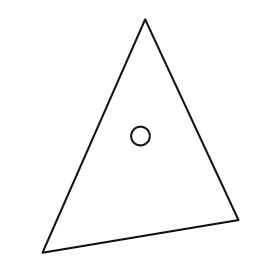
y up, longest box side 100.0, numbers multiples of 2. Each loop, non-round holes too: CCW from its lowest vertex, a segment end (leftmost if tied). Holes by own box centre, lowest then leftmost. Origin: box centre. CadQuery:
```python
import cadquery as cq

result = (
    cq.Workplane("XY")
    .moveTo(-42.0, -50.0)
    .lineTo(42.0, -36.0)
    .lineTo(2.0, 50.0)
    .close()
    .moveTo(0.0, 0.0)
    .circle(4.0)
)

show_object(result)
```